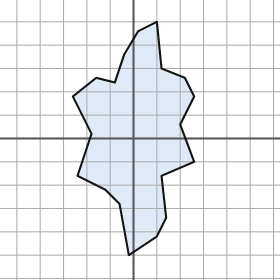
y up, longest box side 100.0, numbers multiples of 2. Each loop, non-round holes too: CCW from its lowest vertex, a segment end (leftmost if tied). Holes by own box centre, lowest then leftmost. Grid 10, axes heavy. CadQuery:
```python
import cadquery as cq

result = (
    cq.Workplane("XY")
    .moveTo(-2.0, -50.0)
    .lineTo(10.0, -42.0)
    .lineTo(14.0, -34.0)
    .lineTo(12.0, -16.0)
    .lineTo(26.0, -10.0)
    .lineTo(20.0, 6.0)
    .lineTo(26.0, 18.0)
    .lineTo(22.0, 26.0)
    .lineTo(12.0, 30.0)
    .lineTo(10.0, 50.0)
    .lineTo(2.0, 46.0)
    .lineTo(-4.0, 36.0)
    .lineTo(-8.0, 24.0)
    .lineTo(-16.0, 26.0)
    .lineTo(-26.0, 18.0)
    .lineTo(-18.0, 2.0)
    .lineTo(-24.0, -16.0)
    .lineTo(-12.0, -22.0)
    .lineTo(-6.0, -28.0)
    .close()
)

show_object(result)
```